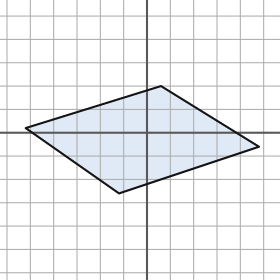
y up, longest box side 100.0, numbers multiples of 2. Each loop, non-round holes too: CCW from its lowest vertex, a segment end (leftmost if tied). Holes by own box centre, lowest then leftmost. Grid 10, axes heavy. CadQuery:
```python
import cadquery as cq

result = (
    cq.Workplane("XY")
    .moveTo(-12.0, -26.0)
    .lineTo(48.0, -6.0)
    .lineTo(6.0, 20.0)
    .lineTo(-52.0, 2.0)
    .close()
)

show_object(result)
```